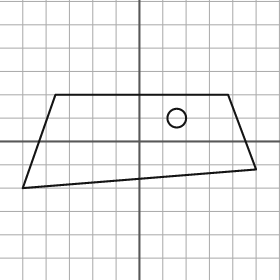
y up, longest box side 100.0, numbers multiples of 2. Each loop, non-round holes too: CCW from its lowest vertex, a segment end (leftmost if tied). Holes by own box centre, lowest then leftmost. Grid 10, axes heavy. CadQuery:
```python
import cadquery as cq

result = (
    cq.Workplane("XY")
    .moveTo(-50.0, -20.0)
    .lineTo(50.0, -12.0)
    .lineTo(38.0, 20.0)
    .lineTo(-36.0, 20.0)
    .close()
    .moveTo(16.0, 10.0)
    .circle(4.0)
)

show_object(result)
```